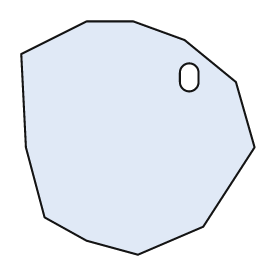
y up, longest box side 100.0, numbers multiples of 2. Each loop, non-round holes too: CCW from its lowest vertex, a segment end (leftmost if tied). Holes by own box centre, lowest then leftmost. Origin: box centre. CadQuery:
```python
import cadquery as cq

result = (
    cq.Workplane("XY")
    .moveTo(0.0, -50.0)
    .lineTo(28.0, -38.0)
    .lineTo(50.0, -4.0)
    .lineTo(42.0, 24.0)
    .lineTo(20.0, 42.0)
    .lineTo(-2.0, 50.0)
    .lineTo(-22.0, 50.0)
    .lineTo(-50.0, 36.0)
    .lineTo(-48.0, -4.0)
    .lineTo(-40.0, -34.0)
    .lineTo(-22.0, -44.0)
    .close()
    .moveTo(18.0, 24.0)
    .threePointArc((22.0, 20.0), (26.0, 24.0))
    .lineTo(26.0, 28.0)
    .threePointArc((22.0, 32.0), (18.0, 28.0))
    .close()
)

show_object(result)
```